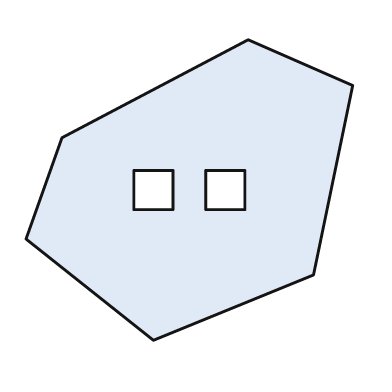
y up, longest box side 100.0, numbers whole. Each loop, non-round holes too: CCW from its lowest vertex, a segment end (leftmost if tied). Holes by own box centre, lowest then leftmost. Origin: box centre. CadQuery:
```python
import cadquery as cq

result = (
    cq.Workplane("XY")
    .moveTo(-11.0, -46.0)
    .lineTo(38.0, -26.0)
    .lineTo(50.0, 32.0)
    .lineTo(18.0, 46.0)
    .lineTo(-39.0, 16.0)
    .lineTo(-50.0, -15.0)
    .close()
    .moveTo(-17.0, -6.0)
    .lineTo(-5.0, -6.0)
    .lineTo(-5.0, 6.0)
    .lineTo(-17.0, 6.0)
    .close()
    .moveTo(5.0, -6.0)
    .lineTo(17.0, -6.0)
    .lineTo(17.0, 6.0)
    .lineTo(5.0, 6.0)
    .close()
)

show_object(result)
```